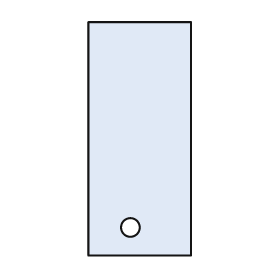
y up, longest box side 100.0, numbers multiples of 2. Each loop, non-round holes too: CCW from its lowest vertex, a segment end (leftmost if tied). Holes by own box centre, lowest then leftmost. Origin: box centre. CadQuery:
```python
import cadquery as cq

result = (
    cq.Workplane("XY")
    .moveTo(-22.0, -50.0)
    .lineTo(22.0, -50.0)
    .lineTo(22.0, 50.0)
    .lineTo(-22.0, 50.0)
    .close()
    .moveTo(-4.0, -38.0)
    .circle(4.0)
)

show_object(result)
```